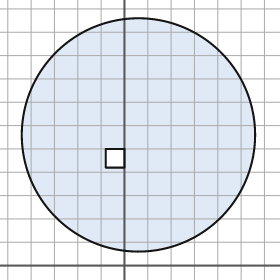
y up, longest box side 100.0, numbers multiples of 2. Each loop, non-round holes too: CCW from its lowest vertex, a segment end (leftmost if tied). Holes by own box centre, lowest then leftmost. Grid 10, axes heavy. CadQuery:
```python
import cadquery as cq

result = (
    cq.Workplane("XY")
    .moveTo(6.0, 56.0)
    .circle(50.0)
    .moveTo(-8.0, 42.0)
    .lineTo(0.0, 42.0)
    .lineTo(0.0, 50.0)
    .lineTo(-8.0, 50.0)
    .close()
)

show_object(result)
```